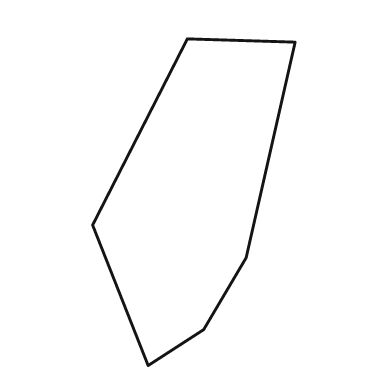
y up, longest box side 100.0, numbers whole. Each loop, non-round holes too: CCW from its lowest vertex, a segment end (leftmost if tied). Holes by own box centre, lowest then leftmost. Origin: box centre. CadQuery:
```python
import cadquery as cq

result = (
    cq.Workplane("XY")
    .moveTo(-14.0, -50.0)
    .lineTo(3.0, -39.0)
    .lineTo(16.0, -17.0)
    .lineTo(31.0, 49.0)
    .lineTo(-2.0, 50.0)
    .lineTo(-31.0, -7.0)
    .close()
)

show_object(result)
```